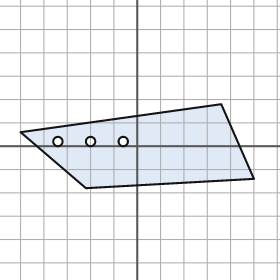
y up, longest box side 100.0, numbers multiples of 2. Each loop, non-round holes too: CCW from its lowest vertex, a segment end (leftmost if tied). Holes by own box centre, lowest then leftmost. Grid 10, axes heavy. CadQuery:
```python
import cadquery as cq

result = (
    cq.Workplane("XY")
    .moveTo(-22.0, -18.0)
    .lineTo(50.0, -14.0)
    .lineTo(36.0, 18.0)
    .lineTo(-50.0, 6.0)
    .close()
    .moveTo(-34.0, 2.0)
    .circle(2.0)
    .moveTo(-20.0, 2.0)
    .circle(2.0)
    .moveTo(-6.0, 2.0)
    .circle(2.0)
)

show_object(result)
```